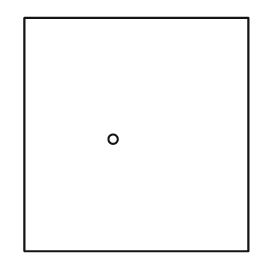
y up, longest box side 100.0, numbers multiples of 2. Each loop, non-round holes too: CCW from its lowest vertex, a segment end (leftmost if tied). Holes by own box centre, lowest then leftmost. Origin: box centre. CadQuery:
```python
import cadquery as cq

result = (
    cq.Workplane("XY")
    .moveTo(-48.0, -50.0)
    .lineTo(48.0, -50.0)
    .lineTo(48.0, 50.0)
    .lineTo(-48.0, 50.0)
    .close()
    .moveTo(-10.0, -2.0)
    .circle(2.0)
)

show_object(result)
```